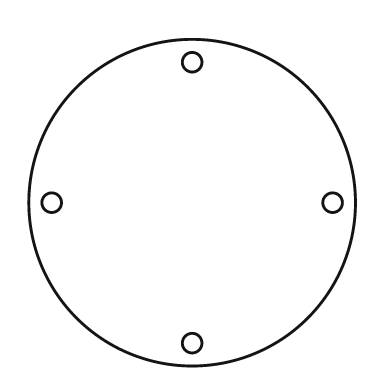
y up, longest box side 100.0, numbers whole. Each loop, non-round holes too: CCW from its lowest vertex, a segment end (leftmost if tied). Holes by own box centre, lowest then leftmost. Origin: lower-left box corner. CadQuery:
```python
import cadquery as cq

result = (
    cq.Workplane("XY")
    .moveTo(50.0, 50.0)
    .circle(50.0)
    .moveTo(50.0, 7.0)
    .circle(3.0)
    .moveTo(7.0, 50.0)
    .circle(3.0)
    .moveTo(93.0, 50.0)
    .circle(3.0)
    .moveTo(50.0, 93.0)
    .circle(3.0)
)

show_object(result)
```